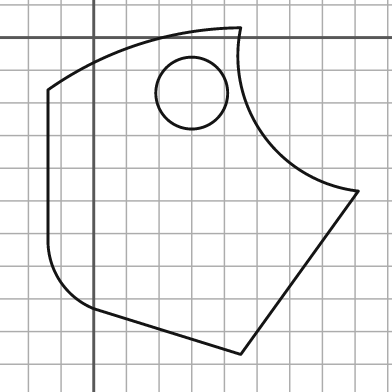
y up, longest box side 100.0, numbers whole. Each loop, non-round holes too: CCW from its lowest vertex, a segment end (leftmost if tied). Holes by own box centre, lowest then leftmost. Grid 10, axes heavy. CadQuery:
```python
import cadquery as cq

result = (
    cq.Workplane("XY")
    .moveTo(45.0, -97.0)
    .lineTo(81.0, -47.0)
    .threePointArc((52.0, -30.0), (45.0, 3.0))
    .threePointArc((14.0, -2.0), (-14.0, -16.0))
    .lineTo(-14.0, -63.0)
    .threePointArc((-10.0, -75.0), (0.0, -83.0))
    .close()
    .moveTo(30.0, -17.0)
    .circle(11.0)
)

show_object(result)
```